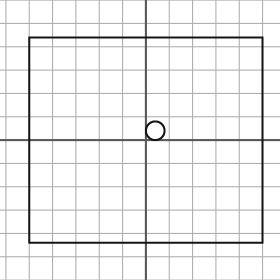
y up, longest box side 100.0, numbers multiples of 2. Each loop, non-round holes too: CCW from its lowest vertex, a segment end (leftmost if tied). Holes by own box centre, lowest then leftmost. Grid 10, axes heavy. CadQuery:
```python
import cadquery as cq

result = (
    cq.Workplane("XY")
    .moveTo(-50.0, -44.0)
    .lineTo(50.0, -44.0)
    .lineTo(50.0, 44.0)
    .lineTo(-50.0, 44.0)
    .close()
    .moveTo(4.0, 4.0)
    .circle(4.0)
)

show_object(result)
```